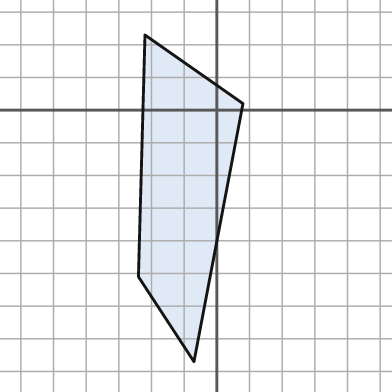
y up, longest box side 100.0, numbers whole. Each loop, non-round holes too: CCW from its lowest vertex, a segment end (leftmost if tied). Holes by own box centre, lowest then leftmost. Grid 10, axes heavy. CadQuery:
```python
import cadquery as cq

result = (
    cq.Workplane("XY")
    .moveTo(-7.0, -77.0)
    .lineTo(8.0, 2.0)
    .lineTo(-22.0, 23.0)
    .lineTo(-24.0, -51.0)
    .close()
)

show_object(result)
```